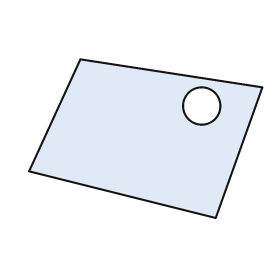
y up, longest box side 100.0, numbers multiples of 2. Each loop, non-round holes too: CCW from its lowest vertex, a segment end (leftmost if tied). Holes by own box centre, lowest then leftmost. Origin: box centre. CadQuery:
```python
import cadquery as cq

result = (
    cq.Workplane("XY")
    .moveTo(30.0, -34.0)
    .lineTo(50.0, 22.0)
    .lineTo(-28.0, 34.0)
    .lineTo(-50.0, -14.0)
    .close()
    .moveTo(24.0, 14.0)
    .circle(8.0)
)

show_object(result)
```